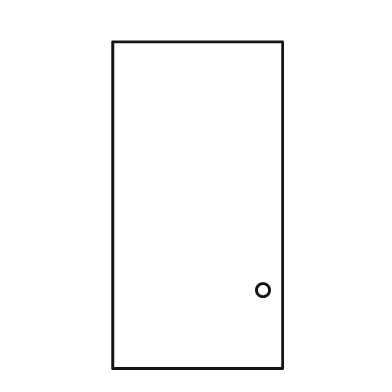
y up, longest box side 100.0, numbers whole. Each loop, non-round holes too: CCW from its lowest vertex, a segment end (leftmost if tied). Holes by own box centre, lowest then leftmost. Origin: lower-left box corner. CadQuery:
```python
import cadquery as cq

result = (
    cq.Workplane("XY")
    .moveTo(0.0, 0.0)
    .lineTo(52.0, 0.0)
    .lineTo(52.0, 100.0)
    .lineTo(0.0, 100.0)
    .close()
    .moveTo(46.0, 24.0)
    .circle(2.0)
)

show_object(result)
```